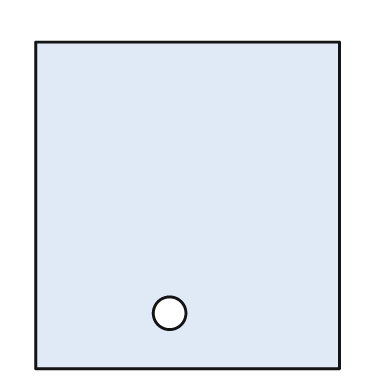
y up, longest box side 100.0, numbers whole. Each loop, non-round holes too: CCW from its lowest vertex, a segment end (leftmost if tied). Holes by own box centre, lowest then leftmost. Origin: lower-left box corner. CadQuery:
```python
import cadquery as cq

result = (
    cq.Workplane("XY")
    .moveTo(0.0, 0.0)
    .lineTo(93.0, 0.0)
    .lineTo(93.0, 100.0)
    .lineTo(0.0, 100.0)
    .close()
    .moveTo(41.0, 17.0)
    .circle(5.0)
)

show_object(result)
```